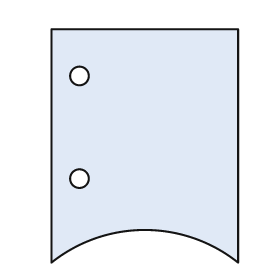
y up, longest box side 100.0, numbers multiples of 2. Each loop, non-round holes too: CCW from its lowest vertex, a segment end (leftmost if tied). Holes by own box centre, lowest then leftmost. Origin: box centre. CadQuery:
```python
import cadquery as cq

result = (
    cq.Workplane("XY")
    .moveTo(-40.0, -50.0)
    .threePointArc((0.0, -36.0), (40.0, -50.0))
    .lineTo(40.0, 50.0)
    .lineTo(-40.0, 50.0)
    .close()
    .moveTo(-28.0, -14.0)
    .circle(4.0)
    .moveTo(-28.0, 30.0)
    .circle(4.0)
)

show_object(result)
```